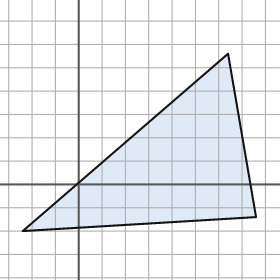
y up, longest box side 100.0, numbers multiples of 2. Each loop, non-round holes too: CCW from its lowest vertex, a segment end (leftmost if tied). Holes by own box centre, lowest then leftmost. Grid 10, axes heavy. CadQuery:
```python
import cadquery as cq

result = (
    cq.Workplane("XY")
    .moveTo(-24.0, -20.0)
    .lineTo(76.0, -14.0)
    .lineTo(64.0, 56.0)
    .close()
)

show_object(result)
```